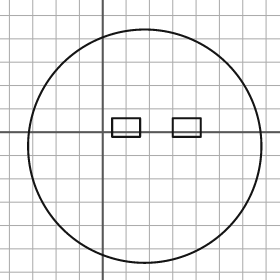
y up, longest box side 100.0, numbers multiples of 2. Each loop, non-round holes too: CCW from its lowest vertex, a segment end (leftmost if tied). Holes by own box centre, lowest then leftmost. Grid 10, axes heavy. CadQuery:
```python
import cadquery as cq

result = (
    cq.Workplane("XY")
    .moveTo(18.0, -6.0)
    .circle(50.0)
    .moveTo(4.0, -2.0)
    .lineTo(16.0, -2.0)
    .lineTo(16.0, 6.0)
    .lineTo(4.0, 6.0)
    .close()
    .moveTo(30.0, -2.0)
    .lineTo(42.0, -2.0)
    .lineTo(42.0, 6.0)
    .lineTo(30.0, 6.0)
    .close()
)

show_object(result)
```